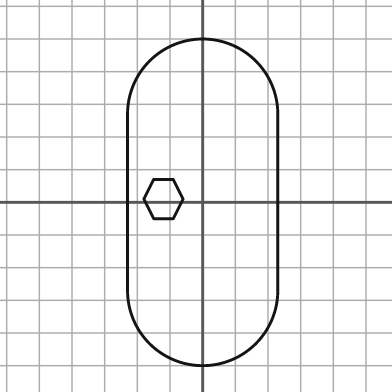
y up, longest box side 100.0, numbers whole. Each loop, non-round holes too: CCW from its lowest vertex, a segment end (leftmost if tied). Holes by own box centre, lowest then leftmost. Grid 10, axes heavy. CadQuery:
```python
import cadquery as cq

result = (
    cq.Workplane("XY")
    .moveTo(-23.0, -27.0)
    .threePointArc((0.0, -50.0), (23.0, -27.0))
    .lineTo(23.0, 27.0)
    .threePointArc((0.0, 50.0), (-23.0, 27.0))
    .close()
    .moveTo(-15.0, -5.0)
    .lineTo(-9.0, -5.0)
    .lineTo(-6.0, 1.0)
    .lineTo(-9.0, 7.0)
    .lineTo(-15.0, 7.0)
    .lineTo(-18.0, 1.0)
    .close()
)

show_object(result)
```